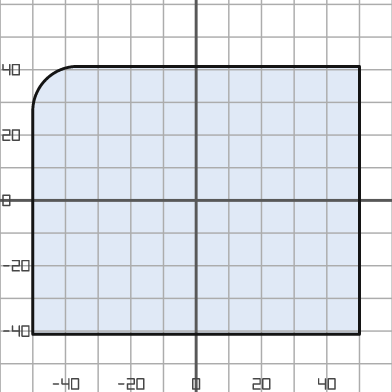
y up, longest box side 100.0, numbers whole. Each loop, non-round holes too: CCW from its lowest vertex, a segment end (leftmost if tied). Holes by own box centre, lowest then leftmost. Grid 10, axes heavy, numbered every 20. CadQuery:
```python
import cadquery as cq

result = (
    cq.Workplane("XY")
    .moveTo(-50.0, -41.0)
    .lineTo(50.0, -41.0)
    .lineTo(50.0, 41.0)
    .lineTo(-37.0, 41.0)
    .threePointArc((-46.0, 37.0), (-50.0, 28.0))
    .close()
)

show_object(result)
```